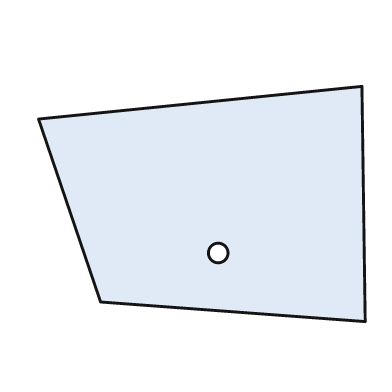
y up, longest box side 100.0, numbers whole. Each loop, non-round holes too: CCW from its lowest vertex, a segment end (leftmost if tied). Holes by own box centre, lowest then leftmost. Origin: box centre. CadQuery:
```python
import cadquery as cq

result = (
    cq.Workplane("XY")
    .moveTo(50.0, -36.0)
    .lineTo(49.0, 36.0)
    .lineTo(-50.0, 26.0)
    .lineTo(-31.0, -30.0)
    .close()
    .moveTo(5.0, -15.0)
    .circle(3.0)
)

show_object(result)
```